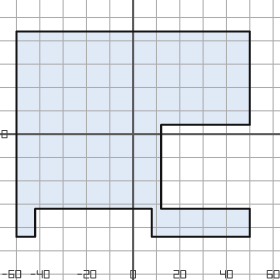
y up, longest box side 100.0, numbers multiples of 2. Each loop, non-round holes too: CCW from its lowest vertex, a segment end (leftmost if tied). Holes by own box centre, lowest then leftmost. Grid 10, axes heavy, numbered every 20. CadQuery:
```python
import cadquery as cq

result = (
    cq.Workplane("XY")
    .moveTo(-50.0, -44.0)
    .lineTo(-42.0, -44.0)
    .lineTo(-42.0, -32.0)
    .lineTo(8.0, -32.0)
    .lineTo(8.0, -44.0)
    .lineTo(50.0, -44.0)
    .lineTo(50.0, -32.0)
    .lineTo(12.0, -32.0)
    .lineTo(12.0, 4.0)
    .lineTo(50.0, 4.0)
    .lineTo(50.0, 44.0)
    .lineTo(-50.0, 44.0)
    .close()
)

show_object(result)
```